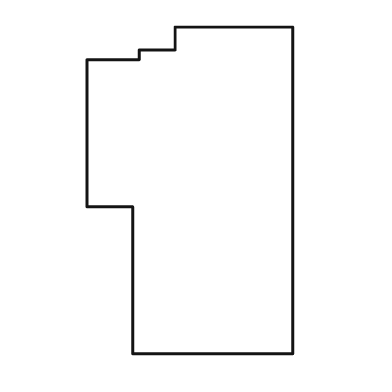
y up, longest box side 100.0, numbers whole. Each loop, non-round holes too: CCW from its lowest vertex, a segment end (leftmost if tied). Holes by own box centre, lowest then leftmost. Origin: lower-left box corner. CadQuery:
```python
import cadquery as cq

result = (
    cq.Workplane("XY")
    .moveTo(14.0, 0.0)
    .lineTo(63.0, 0.0)
    .lineTo(63.0, 100.0)
    .lineTo(27.0, 100.0)
    .lineTo(27.0, 93.0)
    .lineTo(16.0, 93.0)
    .lineTo(16.0, 90.0)
    .lineTo(0.0, 90.0)
    .lineTo(0.0, 45.0)
    .lineTo(14.0, 45.0)
    .close()
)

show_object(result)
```